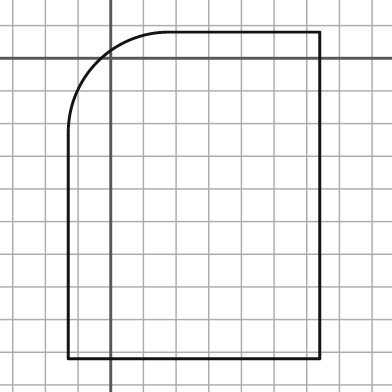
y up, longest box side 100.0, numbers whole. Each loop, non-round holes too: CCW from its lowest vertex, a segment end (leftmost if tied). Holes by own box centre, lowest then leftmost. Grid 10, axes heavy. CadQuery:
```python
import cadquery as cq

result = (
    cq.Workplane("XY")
    .moveTo(-13.0, -92.0)
    .lineTo(64.0, -92.0)
    .lineTo(64.0, 8.0)
    .lineTo(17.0, 8.0)
    .threePointArc((-4.0, -1.0), (-13.0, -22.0))
    .close()
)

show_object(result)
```